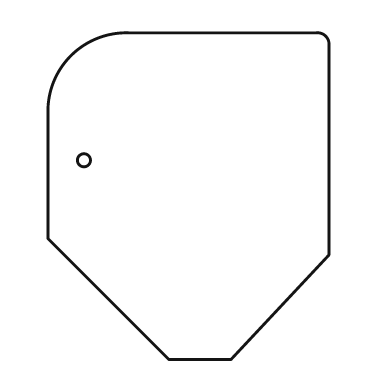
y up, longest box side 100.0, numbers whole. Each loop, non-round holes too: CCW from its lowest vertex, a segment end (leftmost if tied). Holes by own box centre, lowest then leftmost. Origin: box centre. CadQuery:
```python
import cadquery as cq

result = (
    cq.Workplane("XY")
    .moveTo(-6.0, -50.0)
    .lineTo(13.0, -50.0)
    .lineTo(43.0, -18.0)
    .lineTo(43.0, 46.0)
    .threePointArc((42.0, 49.0), (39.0, 50.0))
    .lineTo(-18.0, 50.0)
    .threePointArc((-36.0, 43.0), (-43.0, 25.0))
    .lineTo(-43.0, -13.0)
    .close()
    .moveTo(-32.0, 11.0)
    .circle(2.0)
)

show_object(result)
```